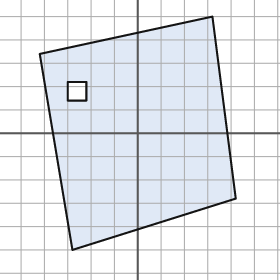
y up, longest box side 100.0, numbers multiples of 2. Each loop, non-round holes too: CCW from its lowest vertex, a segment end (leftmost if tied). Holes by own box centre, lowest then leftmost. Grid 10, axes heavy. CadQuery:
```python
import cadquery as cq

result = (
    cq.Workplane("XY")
    .moveTo(-28.0, -50.0)
    .lineTo(42.0, -28.0)
    .lineTo(32.0, 50.0)
    .lineTo(-42.0, 34.0)
    .close()
    .moveTo(-30.0, 14.0)
    .lineTo(-22.0, 14.0)
    .lineTo(-22.0, 22.0)
    .lineTo(-30.0, 22.0)
    .close()
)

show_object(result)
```